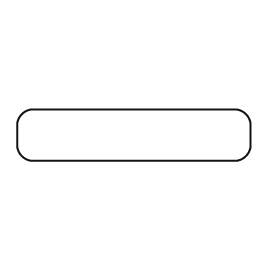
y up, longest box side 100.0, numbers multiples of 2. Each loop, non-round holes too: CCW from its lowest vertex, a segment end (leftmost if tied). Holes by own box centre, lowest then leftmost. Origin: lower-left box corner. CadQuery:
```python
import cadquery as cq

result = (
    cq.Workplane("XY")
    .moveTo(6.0, 0.0)
    .lineTo(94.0, 0.0)
    .threePointArc((98.0, 2.0), (100.0, 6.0))
    .lineTo(100.0, 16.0)
    .threePointArc((98.0, 20.0), (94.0, 22.0))
    .lineTo(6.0, 22.0)
    .threePointArc((2.0, 20.0), (0.0, 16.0))
    .lineTo(0.0, 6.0)
    .threePointArc((2.0, 2.0), (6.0, 0.0))
    .close()
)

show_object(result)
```